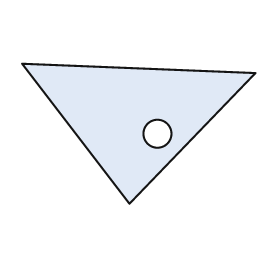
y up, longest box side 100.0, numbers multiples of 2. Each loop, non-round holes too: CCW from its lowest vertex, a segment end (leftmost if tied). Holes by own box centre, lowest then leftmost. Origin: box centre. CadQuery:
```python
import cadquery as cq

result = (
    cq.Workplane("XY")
    .moveTo(-4.0, -30.0)
    .lineTo(50.0, 26.0)
    .lineTo(-50.0, 30.0)
    .close()
    .moveTo(8.0, 0.0)
    .circle(6.0)
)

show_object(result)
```